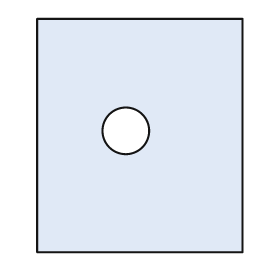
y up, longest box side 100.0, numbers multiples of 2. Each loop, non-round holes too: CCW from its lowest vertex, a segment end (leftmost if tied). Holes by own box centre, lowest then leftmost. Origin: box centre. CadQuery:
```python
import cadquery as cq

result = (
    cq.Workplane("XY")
    .moveTo(-44.0, -50.0)
    .lineTo(44.0, -50.0)
    .lineTo(44.0, 50.0)
    .lineTo(-44.0, 50.0)
    .close()
    .moveTo(-6.0, 2.0)
    .circle(10.0)
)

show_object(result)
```